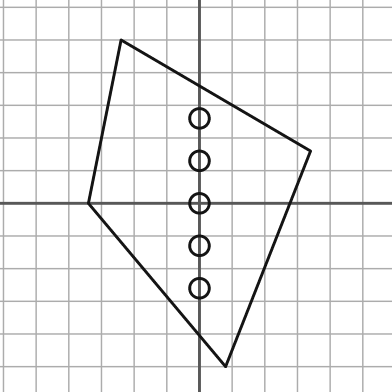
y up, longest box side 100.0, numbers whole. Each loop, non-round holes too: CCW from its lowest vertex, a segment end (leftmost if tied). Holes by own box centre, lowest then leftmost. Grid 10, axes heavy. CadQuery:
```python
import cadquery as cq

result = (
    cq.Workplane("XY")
    .moveTo(8.0, -50.0)
    .lineTo(34.0, 16.0)
    .lineTo(-24.0, 50.0)
    .lineTo(-34.0, 0.0)
    .close()
    .moveTo(0.0, -26.0)
    .circle(3.0)
    .moveTo(0.0, -13.0)
    .circle(3.0)
    .moveTo(0.0, 0.0)
    .circle(3.0)
    .moveTo(0.0, 13.0)
    .circle(3.0)
    .moveTo(0.0, 26.0)
    .circle(3.0)
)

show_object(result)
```